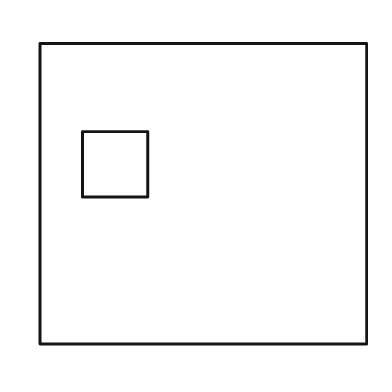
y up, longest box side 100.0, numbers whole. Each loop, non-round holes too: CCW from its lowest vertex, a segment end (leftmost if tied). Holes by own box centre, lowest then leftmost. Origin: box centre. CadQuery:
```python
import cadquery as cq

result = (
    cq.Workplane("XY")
    .moveTo(-50.0, -46.0)
    .lineTo(50.0, -46.0)
    .lineTo(50.0, 46.0)
    .lineTo(-50.0, 46.0)
    .close()
    .moveTo(-37.0, -1.0)
    .lineTo(-17.0, -1.0)
    .lineTo(-17.0, 19.0)
    .lineTo(-37.0, 19.0)
    .close()
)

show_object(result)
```